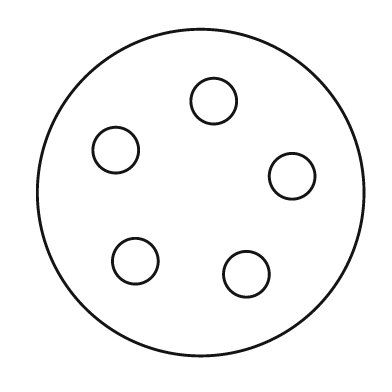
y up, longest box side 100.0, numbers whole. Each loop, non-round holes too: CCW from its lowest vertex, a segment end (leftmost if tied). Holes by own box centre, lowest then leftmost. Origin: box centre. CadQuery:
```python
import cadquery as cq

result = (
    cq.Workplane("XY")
    .moveTo(0.0, 0.0)
    .circle(50.0)
    .moveTo(14.0, -25.0)
    .circle(7.0)
    .moveTo(-20.0, -21.0)
    .circle(7.0)
    .moveTo(28.0, 5.0)
    .circle(7.0)
    .moveTo(-26.0, 13.0)
    .circle(7.0)
    .moveTo(4.0, 28.0)
    .circle(7.0)
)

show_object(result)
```